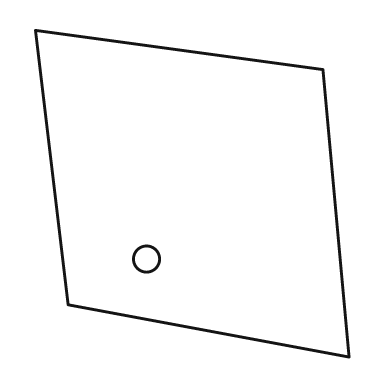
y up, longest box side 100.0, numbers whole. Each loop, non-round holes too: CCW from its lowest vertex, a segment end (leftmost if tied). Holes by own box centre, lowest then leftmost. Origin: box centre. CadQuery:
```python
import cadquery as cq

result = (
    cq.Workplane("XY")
    .moveTo(48.0, -50.0)
    .lineTo(40.0, 38.0)
    .lineTo(-48.0, 50.0)
    .lineTo(-38.0, -34.0)
    .close()
    .moveTo(-14.0, -20.0)
    .circle(4.0)
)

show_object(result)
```